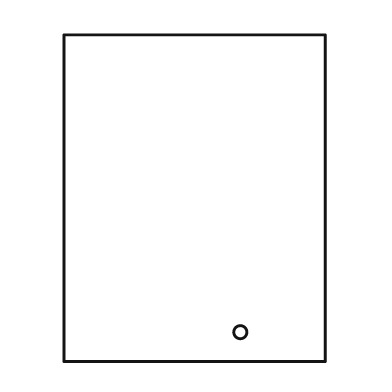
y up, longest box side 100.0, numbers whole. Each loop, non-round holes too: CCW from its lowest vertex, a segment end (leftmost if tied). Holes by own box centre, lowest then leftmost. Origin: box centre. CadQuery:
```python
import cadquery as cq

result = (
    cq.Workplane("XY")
    .moveTo(-40.0, -50.0)
    .lineTo(40.0, -50.0)
    .lineTo(40.0, 50.0)
    .lineTo(-40.0, 50.0)
    .close()
    .moveTo(14.0, -41.0)
    .circle(2.0)
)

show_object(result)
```